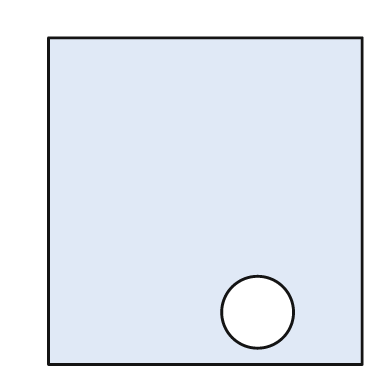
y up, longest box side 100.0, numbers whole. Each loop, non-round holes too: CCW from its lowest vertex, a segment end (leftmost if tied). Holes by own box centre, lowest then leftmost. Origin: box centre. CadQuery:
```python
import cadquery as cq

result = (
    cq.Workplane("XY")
    .moveTo(-48.0, -50.0)
    .lineTo(48.0, -50.0)
    .lineTo(48.0, 50.0)
    .lineTo(-48.0, 50.0)
    .close()
    .moveTo(16.0, -34.0)
    .circle(11.0)
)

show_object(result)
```